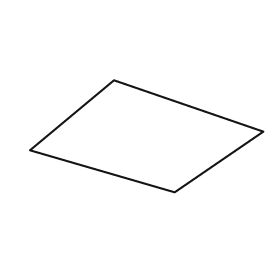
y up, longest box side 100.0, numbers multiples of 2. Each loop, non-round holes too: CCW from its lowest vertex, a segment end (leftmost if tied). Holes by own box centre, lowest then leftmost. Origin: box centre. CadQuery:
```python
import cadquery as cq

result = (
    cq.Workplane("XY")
    .moveTo(12.0, -24.0)
    .lineTo(50.0, 2.0)
    .lineTo(-14.0, 24.0)
    .lineTo(-50.0, -6.0)
    .close()
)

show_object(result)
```